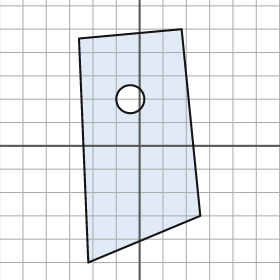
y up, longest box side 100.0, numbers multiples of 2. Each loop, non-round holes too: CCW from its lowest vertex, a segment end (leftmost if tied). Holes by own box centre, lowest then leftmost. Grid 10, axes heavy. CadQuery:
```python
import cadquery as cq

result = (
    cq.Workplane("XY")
    .moveTo(-22.0, -50.0)
    .lineTo(26.0, -30.0)
    .lineTo(18.0, 50.0)
    .lineTo(-26.0, 46.0)
    .close()
    .moveTo(-4.0, 20.0)
    .circle(6.0)
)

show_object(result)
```